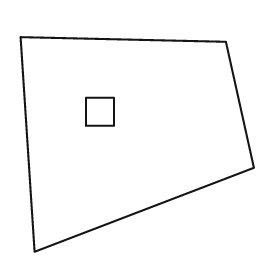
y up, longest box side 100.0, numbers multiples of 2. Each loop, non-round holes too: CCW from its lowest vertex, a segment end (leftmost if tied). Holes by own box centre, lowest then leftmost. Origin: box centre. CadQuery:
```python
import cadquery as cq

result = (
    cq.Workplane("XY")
    .moveTo(-44.0, -46.0)
    .lineTo(50.0, -10.0)
    .lineTo(38.0, 44.0)
    .lineTo(-50.0, 46.0)
    .close()
    .moveTo(-22.0, 8.0)
    .lineTo(-10.0, 8.0)
    .lineTo(-10.0, 20.0)
    .lineTo(-22.0, 20.0)
    .close()
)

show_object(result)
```